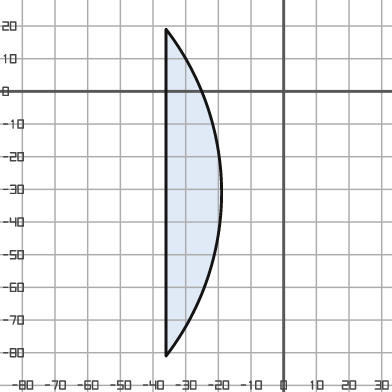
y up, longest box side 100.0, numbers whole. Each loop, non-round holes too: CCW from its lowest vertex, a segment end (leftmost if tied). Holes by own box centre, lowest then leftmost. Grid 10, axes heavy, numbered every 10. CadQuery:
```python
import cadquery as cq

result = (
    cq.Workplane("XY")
    .moveTo(-36.0, -81.0)
    .threePointArc((-19.0, -31.0), (-36.0, 19.0))
    .close()
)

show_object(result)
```